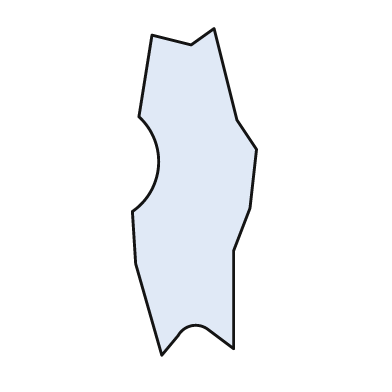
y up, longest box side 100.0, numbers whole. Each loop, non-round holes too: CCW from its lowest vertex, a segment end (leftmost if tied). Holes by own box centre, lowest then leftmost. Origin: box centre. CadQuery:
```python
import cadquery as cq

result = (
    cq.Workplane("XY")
    .moveTo(-10.0, -50.0)
    .lineTo(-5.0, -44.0)
    .threePointArc((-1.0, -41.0), (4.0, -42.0))
    .lineTo(12.0, -48.0)
    .lineTo(12.0, -18.0)
    .lineTo(17.0, -5.0)
    .lineTo(19.0, 13.0)
    .lineTo(13.0, 22.0)
    .lineTo(6.0, 50.0)
    .lineTo(-1.0, 45.0)
    .lineTo(-13.0, 48.0)
    .lineTo(-17.0, 23.0)
    .threePointArc((-11.0, 8.0), (-19.0, -6.0))
    .lineTo(-18.0, -22.0)
    .close()
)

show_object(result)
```